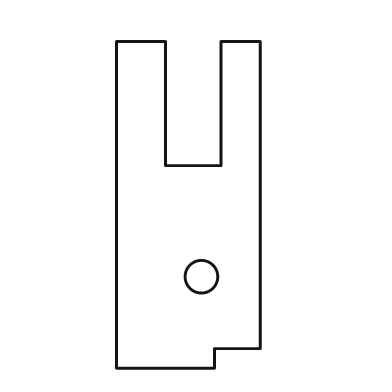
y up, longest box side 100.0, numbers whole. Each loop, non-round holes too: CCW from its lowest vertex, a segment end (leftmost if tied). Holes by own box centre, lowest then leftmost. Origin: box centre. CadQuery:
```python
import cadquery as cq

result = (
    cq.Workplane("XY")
    .moveTo(-22.0, -50.0)
    .lineTo(8.0, -50.0)
    .lineTo(8.0, -44.0)
    .lineTo(22.0, -44.0)
    .lineTo(22.0, 50.0)
    .lineTo(10.0, 50.0)
    .lineTo(10.0, 12.0)
    .lineTo(-7.0, 12.0)
    .lineTo(-7.0, 50.0)
    .lineTo(-22.0, 50.0)
    .close()
    .moveTo(4.0, -22.0)
    .circle(5.0)
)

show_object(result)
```